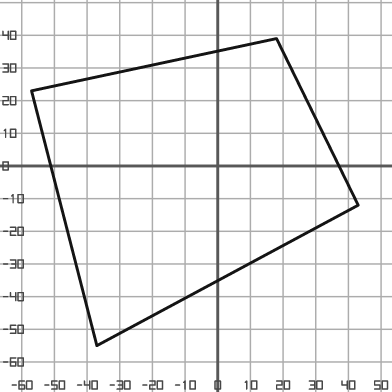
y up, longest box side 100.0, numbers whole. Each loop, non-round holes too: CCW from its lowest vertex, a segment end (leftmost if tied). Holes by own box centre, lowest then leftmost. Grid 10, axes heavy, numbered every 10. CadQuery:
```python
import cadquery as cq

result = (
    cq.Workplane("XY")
    .moveTo(-37.0, -55.0)
    .lineTo(43.0, -12.0)
    .lineTo(18.0, 39.0)
    .lineTo(-57.0, 23.0)
    .close()
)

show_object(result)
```